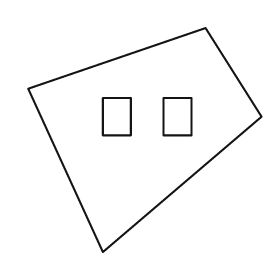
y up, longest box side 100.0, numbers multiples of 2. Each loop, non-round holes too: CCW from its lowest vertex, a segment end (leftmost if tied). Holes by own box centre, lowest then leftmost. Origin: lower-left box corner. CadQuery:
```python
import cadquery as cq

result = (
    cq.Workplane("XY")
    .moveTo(32.0, 0.0)
    .lineTo(100.0, 58.0)
    .lineTo(76.0, 96.0)
    .lineTo(0.0, 70.0)
    .close()
    .moveTo(32.0, 50.0)
    .lineTo(44.0, 50.0)
    .lineTo(44.0, 66.0)
    .lineTo(32.0, 66.0)
    .close()
    .moveTo(58.0, 50.0)
    .lineTo(70.0, 50.0)
    .lineTo(70.0, 66.0)
    .lineTo(58.0, 66.0)
    .close()
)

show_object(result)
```